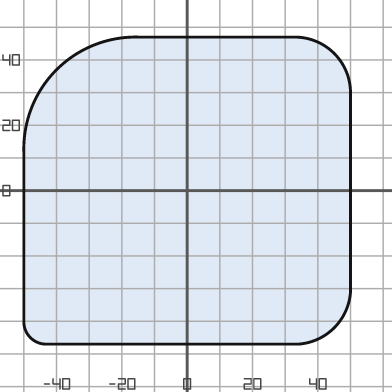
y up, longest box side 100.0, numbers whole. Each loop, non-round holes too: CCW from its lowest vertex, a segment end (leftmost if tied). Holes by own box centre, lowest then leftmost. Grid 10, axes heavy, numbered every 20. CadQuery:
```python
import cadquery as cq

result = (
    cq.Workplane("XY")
    .moveTo(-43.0, -47.0)
    .lineTo(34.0, -47.0)
    .threePointArc((45.0, -42.0), (50.0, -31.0))
    .lineTo(50.0, 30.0)
    .threePointArc((45.0, 42.0), (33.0, 47.0))
    .lineTo(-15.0, 47.0)
    .threePointArc((-40.0, 37.0), (-50.0, 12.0))
    .lineTo(-50.0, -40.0)
    .threePointArc((-48.0, -45.0), (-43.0, -47.0))
    .close()
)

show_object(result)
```